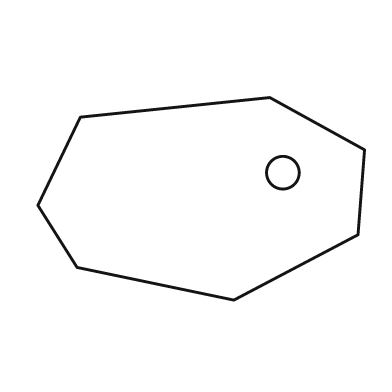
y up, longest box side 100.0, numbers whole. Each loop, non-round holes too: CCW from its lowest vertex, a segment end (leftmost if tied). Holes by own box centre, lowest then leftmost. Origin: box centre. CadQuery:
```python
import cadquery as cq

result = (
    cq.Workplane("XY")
    .moveTo(10.0, -31.0)
    .lineTo(48.0, -11.0)
    .lineTo(50.0, 15.0)
    .lineTo(21.0, 31.0)
    .lineTo(-37.0, 25.0)
    .lineTo(-50.0, -2.0)
    .lineTo(-38.0, -21.0)
    .close()
    .moveTo(25.0, 8.0)
    .circle(5.0)
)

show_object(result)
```